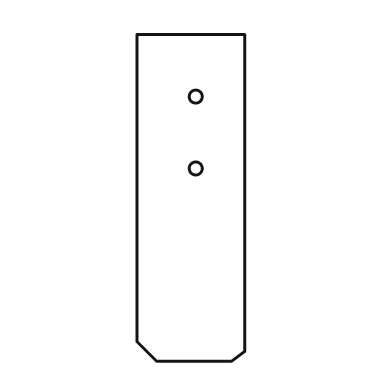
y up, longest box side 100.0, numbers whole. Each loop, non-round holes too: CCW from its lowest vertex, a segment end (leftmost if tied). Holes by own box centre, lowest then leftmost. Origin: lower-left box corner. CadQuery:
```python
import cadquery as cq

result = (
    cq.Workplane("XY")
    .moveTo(6.0, 0.0)
    .lineTo(29.0, 0.0)
    .lineTo(33.0, 3.0)
    .lineTo(33.0, 100.0)
    .lineTo(0.0, 100.0)
    .lineTo(0.0, 6.0)
    .close()
    .moveTo(18.0, 59.0)
    .circle(2.0)
    .moveTo(18.0, 81.0)
    .circle(2.0)
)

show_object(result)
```